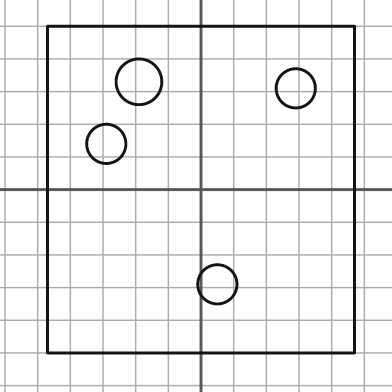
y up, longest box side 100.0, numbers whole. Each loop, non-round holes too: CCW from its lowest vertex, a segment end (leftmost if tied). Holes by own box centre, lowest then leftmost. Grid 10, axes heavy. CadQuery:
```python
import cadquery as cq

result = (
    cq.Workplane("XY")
    .moveTo(-47.0, -50.0)
    .lineTo(47.0, -50.0)
    .lineTo(47.0, 50.0)
    .lineTo(-47.0, 50.0)
    .close()
    .moveTo(5.0, -29.0)
    .circle(6.0)
    .moveTo(-29.0, 14.0)
    .circle(6.0)
    .moveTo(29.0, 31.0)
    .circle(6.0)
    .moveTo(-19.0, 33.0)
    .circle(7.0)
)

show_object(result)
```